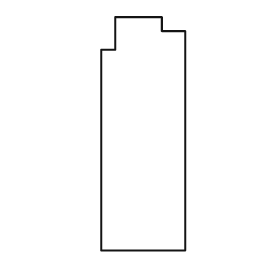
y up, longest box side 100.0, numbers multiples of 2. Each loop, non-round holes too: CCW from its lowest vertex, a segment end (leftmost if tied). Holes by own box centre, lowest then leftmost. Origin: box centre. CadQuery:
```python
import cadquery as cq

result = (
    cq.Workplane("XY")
    .moveTo(-18.0, -50.0)
    .lineTo(18.0, -50.0)
    .lineTo(18.0, 44.0)
    .lineTo(8.0, 44.0)
    .lineTo(8.0, 50.0)
    .lineTo(-12.0, 50.0)
    .lineTo(-12.0, 36.0)
    .lineTo(-18.0, 36.0)
    .close()
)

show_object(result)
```